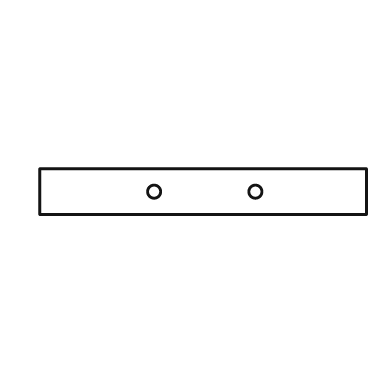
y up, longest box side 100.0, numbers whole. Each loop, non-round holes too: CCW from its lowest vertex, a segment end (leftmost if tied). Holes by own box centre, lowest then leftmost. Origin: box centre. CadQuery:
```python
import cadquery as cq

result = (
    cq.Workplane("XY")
    .moveTo(-50.0, -7.0)
    .lineTo(50.0, -7.0)
    .lineTo(50.0, 7.0)
    .lineTo(-50.0, 7.0)
    .close()
    .moveTo(-15.0, 0.0)
    .circle(2.0)
    .moveTo(16.0, 0.0)
    .circle(2.0)
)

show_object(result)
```